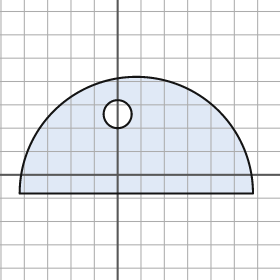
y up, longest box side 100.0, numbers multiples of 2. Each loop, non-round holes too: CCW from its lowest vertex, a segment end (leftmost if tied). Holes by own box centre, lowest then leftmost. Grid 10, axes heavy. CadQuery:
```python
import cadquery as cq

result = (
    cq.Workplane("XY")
    .moveTo(-42.0, -8.0)
    .lineTo(58.0, -8.0)
    .threePointArc((8.0, 42.0), (-42.0, -8.0))
    .close()
    .moveTo(0.0, 26.0)
    .circle(6.0)
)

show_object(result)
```